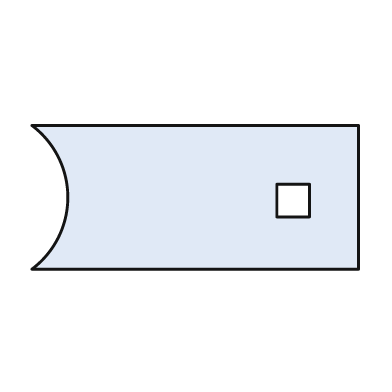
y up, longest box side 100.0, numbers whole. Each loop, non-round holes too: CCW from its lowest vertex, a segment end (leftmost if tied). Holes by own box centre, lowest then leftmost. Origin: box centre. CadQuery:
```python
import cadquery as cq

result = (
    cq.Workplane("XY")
    .moveTo(-50.0, -22.0)
    .lineTo(50.0, -22.0)
    .lineTo(50.0, 22.0)
    .lineTo(-50.0, 22.0)
    .threePointArc((-39.0, 0.0), (-50.0, -22.0))
    .close()
    .moveTo(25.0, -6.0)
    .lineTo(35.0, -6.0)
    .lineTo(35.0, 4.0)
    .lineTo(25.0, 4.0)
    .close()
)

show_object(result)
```